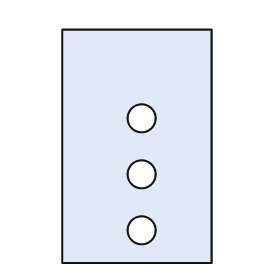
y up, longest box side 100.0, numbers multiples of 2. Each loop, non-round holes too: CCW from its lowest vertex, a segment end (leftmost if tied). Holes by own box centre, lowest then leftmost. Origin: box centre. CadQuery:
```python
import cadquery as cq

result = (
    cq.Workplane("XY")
    .moveTo(-32.0, -50.0)
    .lineTo(32.0, -50.0)
    .lineTo(32.0, 50.0)
    .lineTo(-32.0, 50.0)
    .close()
    .moveTo(2.0, -36.0)
    .circle(6.0)
    .moveTo(2.0, -12.0)
    .circle(6.0)
    .moveTo(2.0, 12.0)
    .circle(6.0)
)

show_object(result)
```